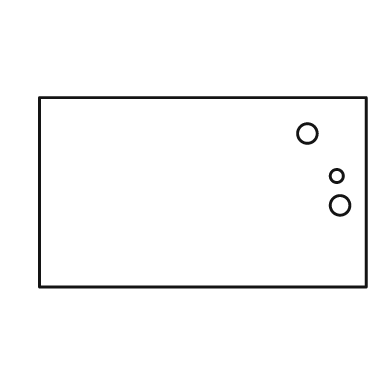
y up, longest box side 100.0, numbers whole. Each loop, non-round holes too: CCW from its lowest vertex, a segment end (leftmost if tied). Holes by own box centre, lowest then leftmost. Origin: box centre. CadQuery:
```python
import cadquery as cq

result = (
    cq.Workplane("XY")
    .moveTo(-50.0, -29.0)
    .lineTo(50.0, -29.0)
    .lineTo(50.0, 29.0)
    .lineTo(-50.0, 29.0)
    .close()
    .moveTo(42.0, -4.0)
    .circle(3.0)
    .moveTo(41.0, 5.0)
    .circle(2.0)
    .moveTo(32.0, 18.0)
    .circle(3.0)
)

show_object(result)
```